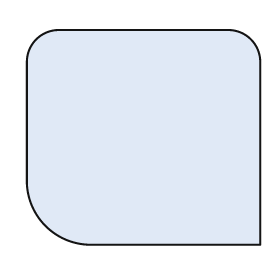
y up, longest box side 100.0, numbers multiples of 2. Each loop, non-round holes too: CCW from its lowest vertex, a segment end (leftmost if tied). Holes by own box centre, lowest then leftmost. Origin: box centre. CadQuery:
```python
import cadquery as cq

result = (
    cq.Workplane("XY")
    .moveTo(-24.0, -46.0)
    .lineTo(50.0, -46.0)
    .lineTo(50.0, 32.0)
    .threePointArc((46.0, 42.0), (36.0, 46.0))
    .lineTo(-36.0, 46.0)
    .threePointArc((-46.0, 42.0), (-50.0, 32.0))
    .lineTo(-50.0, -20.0)
    .threePointArc((-42.0, -38.0), (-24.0, -46.0))
    .close()
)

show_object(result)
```